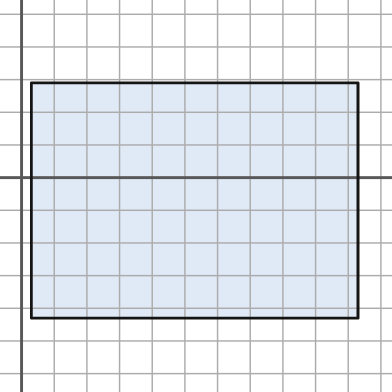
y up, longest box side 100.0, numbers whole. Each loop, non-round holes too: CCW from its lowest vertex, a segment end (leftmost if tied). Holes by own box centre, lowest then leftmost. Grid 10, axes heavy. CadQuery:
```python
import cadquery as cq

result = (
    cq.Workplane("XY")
    .moveTo(3.0, -43.0)
    .lineTo(103.0, -43.0)
    .lineTo(103.0, 29.0)
    .lineTo(3.0, 29.0)
    .close()
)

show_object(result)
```